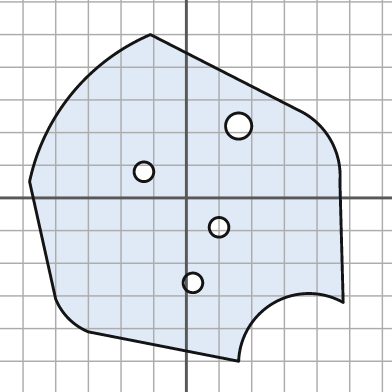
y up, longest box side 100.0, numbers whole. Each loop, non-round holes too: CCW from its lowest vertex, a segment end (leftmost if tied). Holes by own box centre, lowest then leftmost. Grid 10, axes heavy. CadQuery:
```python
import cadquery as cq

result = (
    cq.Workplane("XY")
    .moveTo(16.0, -50.0)
    .threePointArc((27.0, -32.0), (48.0, -32.0))
    .lineTo(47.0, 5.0)
    .threePointArc((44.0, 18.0), (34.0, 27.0))
    .lineTo(-11.0, 50.0)
    .threePointArc((-35.0, 32.0), (-48.0, 5.0))
    .lineTo(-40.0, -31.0)
    .threePointArc((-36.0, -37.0), (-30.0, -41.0))
    .close()
    .moveTo(2.0, -26.0)
    .circle(3.0)
    .moveTo(10.0, -9.0)
    .circle(3.0)
    .moveTo(-13.0, 8.0)
    .circle(3.0)
    .moveTo(16.0, 22.0)
    .circle(4.0)
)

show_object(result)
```